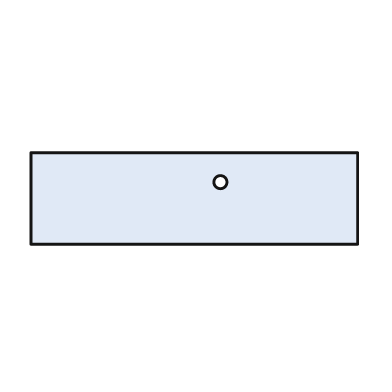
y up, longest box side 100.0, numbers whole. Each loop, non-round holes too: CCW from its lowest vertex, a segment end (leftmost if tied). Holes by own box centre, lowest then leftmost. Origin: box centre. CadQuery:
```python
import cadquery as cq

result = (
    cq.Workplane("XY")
    .moveTo(-50.0, -14.0)
    .lineTo(50.0, -14.0)
    .lineTo(50.0, 14.0)
    .lineTo(-50.0, 14.0)
    .close()
    .moveTo(8.0, 5.0)
    .circle(2.0)
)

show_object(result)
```